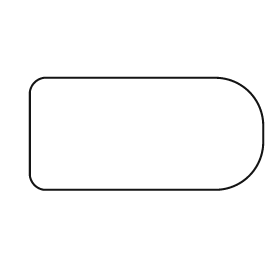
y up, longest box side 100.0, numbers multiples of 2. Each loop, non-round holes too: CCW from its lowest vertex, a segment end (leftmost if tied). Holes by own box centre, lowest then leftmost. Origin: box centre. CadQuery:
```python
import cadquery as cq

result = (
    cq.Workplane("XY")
    .moveTo(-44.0, -24.0)
    .lineTo(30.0, -24.0)
    .threePointArc((44.0, -18.0), (50.0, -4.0))
    .lineTo(50.0, 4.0)
    .threePointArc((44.0, 18.0), (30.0, 24.0))
    .lineTo(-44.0, 24.0)
    .threePointArc((-48.0, 22.0), (-50.0, 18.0))
    .lineTo(-50.0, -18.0)
    .threePointArc((-48.0, -22.0), (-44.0, -24.0))
    .close()
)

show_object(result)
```